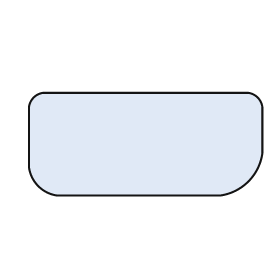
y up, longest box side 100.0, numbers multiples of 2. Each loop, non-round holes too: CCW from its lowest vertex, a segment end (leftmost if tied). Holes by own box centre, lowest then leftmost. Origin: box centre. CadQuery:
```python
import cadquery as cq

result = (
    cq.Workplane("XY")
    .moveTo(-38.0, -22.0)
    .lineTo(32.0, -22.0)
    .threePointArc((44.0, -16.0), (50.0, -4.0))
    .lineTo(50.0, 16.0)
    .threePointArc((48.0, 20.0), (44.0, 22.0))
    .lineTo(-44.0, 22.0)
    .threePointArc((-48.0, 20.0), (-50.0, 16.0))
    .lineTo(-50.0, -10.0)
    .threePointArc((-46.0, -18.0), (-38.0, -22.0))
    .close()
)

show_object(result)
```